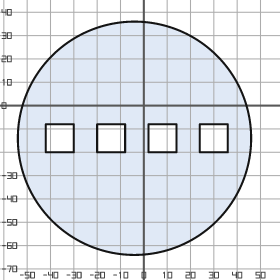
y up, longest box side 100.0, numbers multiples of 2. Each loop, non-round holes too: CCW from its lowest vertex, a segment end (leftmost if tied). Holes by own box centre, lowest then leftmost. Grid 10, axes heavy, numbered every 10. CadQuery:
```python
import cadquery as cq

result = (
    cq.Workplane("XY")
    .moveTo(-4.0, -14.0)
    .circle(50.0)
    .moveTo(-42.0, -20.0)
    .lineTo(-30.0, -20.0)
    .lineTo(-30.0, -8.0)
    .lineTo(-42.0, -8.0)
    .close()
    .moveTo(-20.0, -20.0)
    .lineTo(-8.0, -20.0)
    .lineTo(-8.0, -8.0)
    .lineTo(-20.0, -8.0)
    .close()
    .moveTo(2.0, -20.0)
    .lineTo(14.0, -20.0)
    .lineTo(14.0, -8.0)
    .lineTo(2.0, -8.0)
    .close()
    .moveTo(24.0, -20.0)
    .lineTo(36.0, -20.0)
    .lineTo(36.0, -8.0)
    .lineTo(24.0, -8.0)
    .close()
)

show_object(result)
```